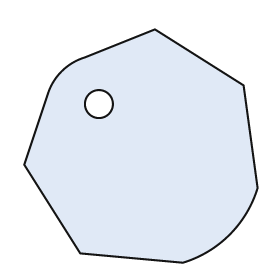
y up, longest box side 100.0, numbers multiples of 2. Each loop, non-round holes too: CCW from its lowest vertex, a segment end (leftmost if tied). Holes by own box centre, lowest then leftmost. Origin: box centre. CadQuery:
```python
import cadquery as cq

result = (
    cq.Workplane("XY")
    .moveTo(18.0, -50.0)
    .threePointArc((38.0, -38.0), (50.0, -18.0))
    .lineTo(44.0, 26.0)
    .lineTo(6.0, 50.0)
    .lineTo(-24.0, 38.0)
    .threePointArc((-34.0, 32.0), (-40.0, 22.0))
    .lineTo(-50.0, -8.0)
    .lineTo(-26.0, -46.0)
    .close()
    .moveTo(-18.0, 18.0)
    .circle(6.0)
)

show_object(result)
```